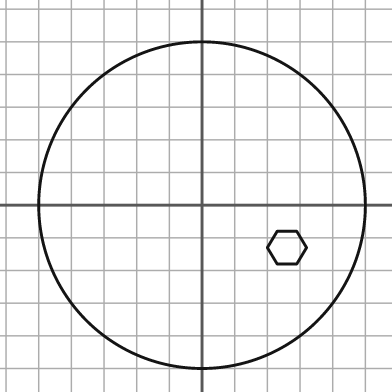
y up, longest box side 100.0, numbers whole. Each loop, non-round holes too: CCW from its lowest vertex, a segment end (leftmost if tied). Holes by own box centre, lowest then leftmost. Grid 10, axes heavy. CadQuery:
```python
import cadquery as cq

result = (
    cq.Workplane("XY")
    .moveTo(0.0, 0.0)
    .circle(50.0)
    .moveTo(23.0, -18.0)
    .lineTo(29.0, -18.0)
    .lineTo(32.0, -13.0)
    .lineTo(29.0, -8.0)
    .lineTo(23.0, -8.0)
    .lineTo(20.0, -13.0)
    .close()
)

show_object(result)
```